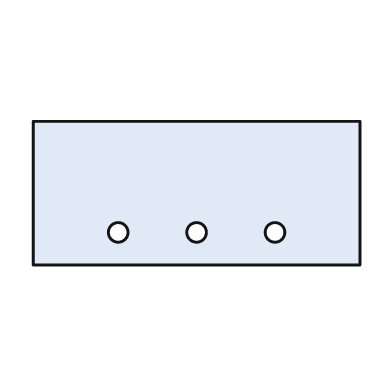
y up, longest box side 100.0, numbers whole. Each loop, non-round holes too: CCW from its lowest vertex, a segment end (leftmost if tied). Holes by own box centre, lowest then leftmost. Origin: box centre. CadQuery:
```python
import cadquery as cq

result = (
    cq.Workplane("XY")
    .moveTo(-50.0, -22.0)
    .lineTo(50.0, -22.0)
    .lineTo(50.0, 22.0)
    .lineTo(-50.0, 22.0)
    .close()
    .moveTo(-24.0, -12.0)
    .circle(3.0)
    .moveTo(0.0, -12.0)
    .circle(3.0)
    .moveTo(24.0, -12.0)
    .circle(3.0)
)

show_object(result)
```